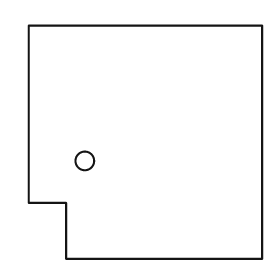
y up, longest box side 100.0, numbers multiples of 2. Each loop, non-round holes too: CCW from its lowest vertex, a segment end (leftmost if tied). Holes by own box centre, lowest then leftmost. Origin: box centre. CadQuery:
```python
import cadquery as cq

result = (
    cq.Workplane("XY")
    .moveTo(-34.0, -50.0)
    .lineTo(50.0, -50.0)
    .lineTo(50.0, 50.0)
    .lineTo(-50.0, 50.0)
    .lineTo(-50.0, -26.0)
    .lineTo(-34.0, -26.0)
    .close()
    .moveTo(-26.0, -8.0)
    .circle(4.0)
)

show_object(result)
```